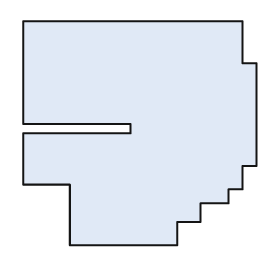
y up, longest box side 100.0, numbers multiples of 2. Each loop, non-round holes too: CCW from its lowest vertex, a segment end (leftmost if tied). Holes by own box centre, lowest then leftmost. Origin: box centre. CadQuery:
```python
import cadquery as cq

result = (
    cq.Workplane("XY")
    .moveTo(-30.0, -48.0)
    .lineTo(16.0, -48.0)
    .lineTo(16.0, -38.0)
    .lineTo(26.0, -38.0)
    .lineTo(26.0, -30.0)
    .lineTo(38.0, -30.0)
    .lineTo(38.0, -24.0)
    .lineTo(44.0, -24.0)
    .lineTo(44.0, -14.0)
    .lineTo(50.0, -14.0)
    .lineTo(50.0, 30.0)
    .lineTo(44.0, 30.0)
    .lineTo(44.0, 48.0)
    .lineTo(-50.0, 48.0)
    .lineTo(-50.0, 4.0)
    .lineTo(-4.0, 4.0)
    .lineTo(-4.0, 0.0)
    .lineTo(-50.0, 0.0)
    .lineTo(-50.0, -22.0)
    .lineTo(-30.0, -22.0)
    .close()
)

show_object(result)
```